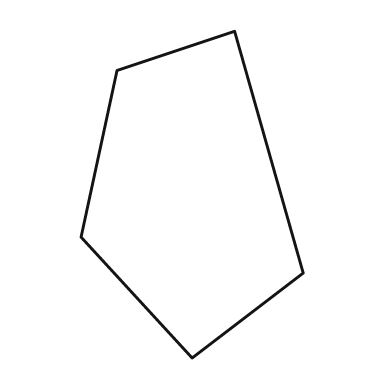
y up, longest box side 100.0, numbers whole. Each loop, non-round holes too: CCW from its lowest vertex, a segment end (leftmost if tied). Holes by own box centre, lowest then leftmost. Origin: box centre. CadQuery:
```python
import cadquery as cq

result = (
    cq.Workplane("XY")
    .moveTo(0.0, -50.0)
    .lineTo(34.0, -24.0)
    .lineTo(13.0, 50.0)
    .lineTo(-23.0, 38.0)
    .lineTo(-34.0, -13.0)
    .close()
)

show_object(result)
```